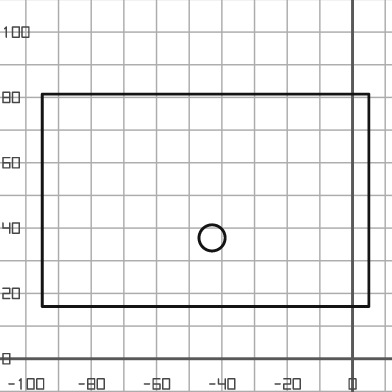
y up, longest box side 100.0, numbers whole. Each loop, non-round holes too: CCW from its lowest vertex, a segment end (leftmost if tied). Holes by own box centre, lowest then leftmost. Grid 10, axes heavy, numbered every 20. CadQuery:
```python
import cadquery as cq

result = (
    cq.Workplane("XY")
    .moveTo(-95.0, 16.0)
    .lineTo(5.0, 16.0)
    .lineTo(5.0, 81.0)
    .lineTo(-95.0, 81.0)
    .close()
    .moveTo(-43.0, 37.0)
    .circle(4.0)
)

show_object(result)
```